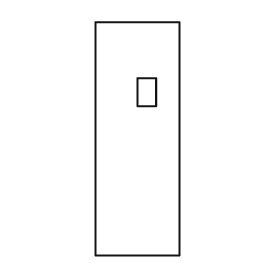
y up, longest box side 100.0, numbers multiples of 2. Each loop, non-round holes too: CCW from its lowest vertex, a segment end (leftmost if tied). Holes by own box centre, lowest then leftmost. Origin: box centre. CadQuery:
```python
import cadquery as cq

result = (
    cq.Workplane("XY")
    .moveTo(-18.0, -50.0)
    .lineTo(18.0, -50.0)
    .lineTo(18.0, 50.0)
    .lineTo(-18.0, 50.0)
    .close()
    .moveTo(0.0, 14.0)
    .lineTo(8.0, 14.0)
    .lineTo(8.0, 26.0)
    .lineTo(0.0, 26.0)
    .close()
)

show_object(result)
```